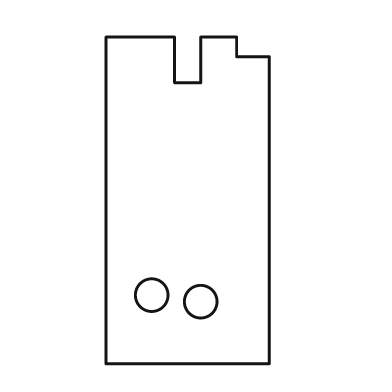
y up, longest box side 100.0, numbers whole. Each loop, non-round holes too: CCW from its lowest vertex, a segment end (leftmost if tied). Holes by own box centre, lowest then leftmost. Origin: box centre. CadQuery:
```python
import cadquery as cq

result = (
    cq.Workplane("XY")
    .moveTo(-25.0, -50.0)
    .lineTo(25.0, -50.0)
    .lineTo(25.0, 44.0)
    .lineTo(15.0, 44.0)
    .lineTo(15.0, 50.0)
    .lineTo(4.0, 50.0)
    .lineTo(4.0, 36.0)
    .lineTo(-4.0, 36.0)
    .lineTo(-4.0, 50.0)
    .lineTo(-25.0, 50.0)
    .close()
    .moveTo(4.0, -31.0)
    .circle(5.0)
    .moveTo(-11.0, -29.0)
    .circle(5.0)
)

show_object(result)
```